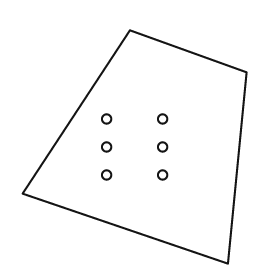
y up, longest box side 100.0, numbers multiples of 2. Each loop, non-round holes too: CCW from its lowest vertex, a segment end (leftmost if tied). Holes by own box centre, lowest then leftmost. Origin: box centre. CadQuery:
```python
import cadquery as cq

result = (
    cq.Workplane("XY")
    .moveTo(40.0, -50.0)
    .lineTo(48.0, 32.0)
    .lineTo(-2.0, 50.0)
    .lineTo(-48.0, -20.0)
    .close()
    .moveTo(-12.0, -12.0)
    .circle(2.0)
    .moveTo(12.0, -12.0)
    .circle(2.0)
    .moveTo(-12.0, 0.0)
    .circle(2.0)
    .moveTo(12.0, 0.0)
    .circle(2.0)
    .moveTo(-12.0, 12.0)
    .circle(2.0)
    .moveTo(12.0, 12.0)
    .circle(2.0)
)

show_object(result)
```